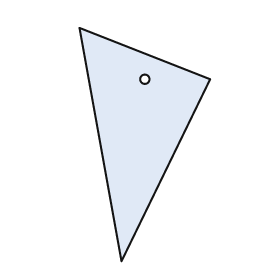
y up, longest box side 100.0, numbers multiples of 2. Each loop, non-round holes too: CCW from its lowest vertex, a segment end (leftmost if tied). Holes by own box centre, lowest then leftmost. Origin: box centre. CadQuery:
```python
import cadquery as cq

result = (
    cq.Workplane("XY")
    .moveTo(-10.0, -50.0)
    .lineTo(28.0, 28.0)
    .lineTo(-28.0, 50.0)
    .close()
    .moveTo(0.0, 28.0)
    .circle(2.0)
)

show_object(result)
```